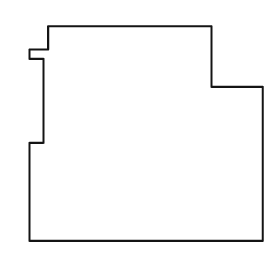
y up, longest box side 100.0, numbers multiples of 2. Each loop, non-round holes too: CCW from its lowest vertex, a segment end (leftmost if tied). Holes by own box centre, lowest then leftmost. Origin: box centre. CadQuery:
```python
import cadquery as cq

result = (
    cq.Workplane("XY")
    .moveTo(-50.0, -46.0)
    .lineTo(50.0, -46.0)
    .lineTo(50.0, 20.0)
    .lineTo(28.0, 20.0)
    .lineTo(28.0, 46.0)
    .lineTo(-42.0, 46.0)
    .lineTo(-42.0, 36.0)
    .lineTo(-50.0, 36.0)
    .lineTo(-50.0, 32.0)
    .lineTo(-44.0, 32.0)
    .lineTo(-44.0, -4.0)
    .lineTo(-50.0, -4.0)
    .close()
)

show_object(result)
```